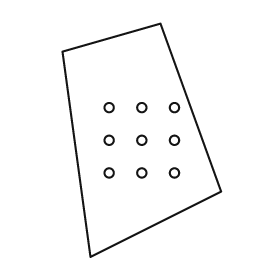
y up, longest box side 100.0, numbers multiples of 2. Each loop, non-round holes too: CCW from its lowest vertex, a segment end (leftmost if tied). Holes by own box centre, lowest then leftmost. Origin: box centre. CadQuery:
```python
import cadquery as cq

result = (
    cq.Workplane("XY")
    .moveTo(-22.0, -50.0)
    .lineTo(34.0, -22.0)
    .lineTo(8.0, 50.0)
    .lineTo(-34.0, 38.0)
    .close()
    .moveTo(-14.0, -14.0)
    .circle(2.0)
    .moveTo(0.0, -14.0)
    .circle(2.0)
    .moveTo(14.0, -14.0)
    .circle(2.0)
    .moveTo(-14.0, 0.0)
    .circle(2.0)
    .moveTo(0.0, 0.0)
    .circle(2.0)
    .moveTo(14.0, 0.0)
    .circle(2.0)
    .moveTo(-14.0, 14.0)
    .circle(2.0)
    .moveTo(0.0, 14.0)
    .circle(2.0)
    .moveTo(14.0, 14.0)
    .circle(2.0)
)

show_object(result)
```